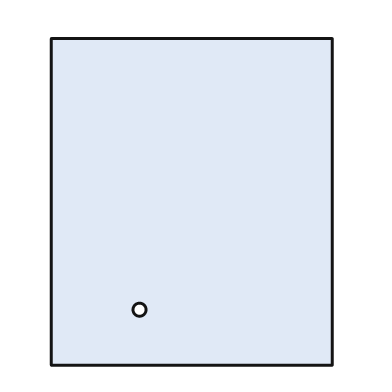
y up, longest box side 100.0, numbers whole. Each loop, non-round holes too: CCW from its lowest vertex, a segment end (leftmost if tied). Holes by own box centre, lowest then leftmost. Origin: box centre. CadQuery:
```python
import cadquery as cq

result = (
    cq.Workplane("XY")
    .moveTo(-43.0, -50.0)
    .lineTo(43.0, -50.0)
    .lineTo(43.0, 50.0)
    .lineTo(-43.0, 50.0)
    .close()
    .moveTo(-16.0, -33.0)
    .circle(2.0)
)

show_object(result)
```